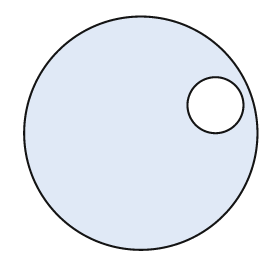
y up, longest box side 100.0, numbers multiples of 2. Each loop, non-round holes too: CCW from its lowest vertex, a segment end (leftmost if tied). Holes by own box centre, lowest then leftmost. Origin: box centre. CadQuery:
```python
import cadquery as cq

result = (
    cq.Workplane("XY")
    .moveTo(0.0, 0.0)
    .circle(50.0)
    .moveTo(32.0, 12.0)
    .circle(12.0)
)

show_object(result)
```